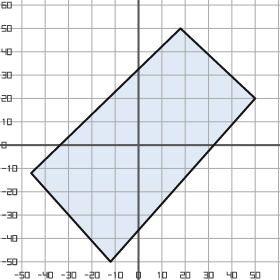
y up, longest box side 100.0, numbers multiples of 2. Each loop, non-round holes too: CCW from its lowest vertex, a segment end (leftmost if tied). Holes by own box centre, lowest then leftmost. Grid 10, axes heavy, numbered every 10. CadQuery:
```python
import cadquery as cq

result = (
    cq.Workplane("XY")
    .moveTo(-12.0, -50.0)
    .lineTo(50.0, 20.0)
    .lineTo(18.0, 50.0)
    .lineTo(-46.0, -12.0)
    .close()
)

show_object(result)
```